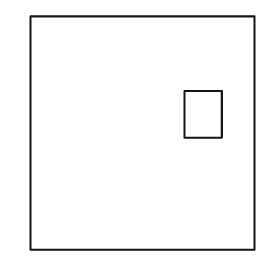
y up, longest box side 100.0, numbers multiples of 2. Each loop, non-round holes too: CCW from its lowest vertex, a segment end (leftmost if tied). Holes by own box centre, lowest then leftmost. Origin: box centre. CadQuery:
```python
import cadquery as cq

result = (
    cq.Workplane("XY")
    .moveTo(-48.0, -50.0)
    .lineTo(48.0, -50.0)
    .lineTo(48.0, 50.0)
    .lineTo(-48.0, 50.0)
    .close()
    .moveTo(18.0, -2.0)
    .lineTo(34.0, -2.0)
    .lineTo(34.0, 18.0)
    .lineTo(18.0, 18.0)
    .close()
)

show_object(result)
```